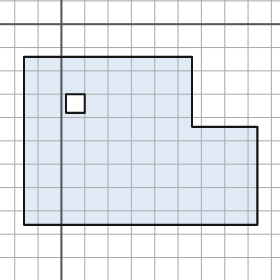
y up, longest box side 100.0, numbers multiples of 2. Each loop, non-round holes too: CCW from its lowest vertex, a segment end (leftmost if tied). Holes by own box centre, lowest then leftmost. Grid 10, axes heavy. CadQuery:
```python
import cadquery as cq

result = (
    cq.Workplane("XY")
    .moveTo(-16.0, -86.0)
    .lineTo(84.0, -86.0)
    .lineTo(84.0, -44.0)
    .lineTo(56.0, -44.0)
    .lineTo(56.0, -14.0)
    .lineTo(-16.0, -14.0)
    .close()
    .moveTo(2.0, -38.0)
    .lineTo(10.0, -38.0)
    .lineTo(10.0, -30.0)
    .lineTo(2.0, -30.0)
    .close()
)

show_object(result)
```